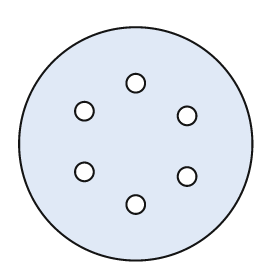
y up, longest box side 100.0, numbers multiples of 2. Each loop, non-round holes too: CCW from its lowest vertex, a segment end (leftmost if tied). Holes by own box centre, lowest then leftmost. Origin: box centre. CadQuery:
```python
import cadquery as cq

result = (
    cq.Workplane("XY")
    .moveTo(0.0, 0.0)
    .circle(50.0)
    .moveTo(0.0, -26.0)
    .circle(4.0)
    .moveTo(22.0, -14.0)
    .circle(4.0)
    .moveTo(-22.0, -12.0)
    .circle(4.0)
    .moveTo(22.0, 12.0)
    .circle(4.0)
    .moveTo(-22.0, 14.0)
    .circle(4.0)
    .moveTo(0.0, 26.0)
    .circle(4.0)
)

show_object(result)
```